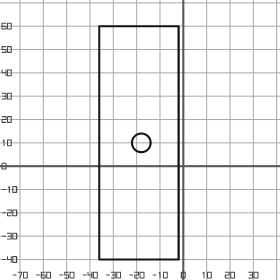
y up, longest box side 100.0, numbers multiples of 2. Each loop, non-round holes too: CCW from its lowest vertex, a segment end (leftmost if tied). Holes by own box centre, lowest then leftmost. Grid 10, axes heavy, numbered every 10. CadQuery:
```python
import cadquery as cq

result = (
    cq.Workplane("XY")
    .moveTo(-36.0, -40.0)
    .lineTo(-2.0, -40.0)
    .lineTo(-2.0, 60.0)
    .lineTo(-36.0, 60.0)
    .close()
    .moveTo(-18.0, 10.0)
    .circle(4.0)
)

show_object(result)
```